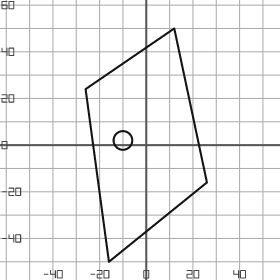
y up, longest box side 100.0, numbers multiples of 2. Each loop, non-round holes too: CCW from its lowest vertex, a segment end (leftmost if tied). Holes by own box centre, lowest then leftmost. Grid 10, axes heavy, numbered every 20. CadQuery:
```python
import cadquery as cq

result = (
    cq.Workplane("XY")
    .moveTo(-16.0, -50.0)
    .lineTo(26.0, -16.0)
    .lineTo(12.0, 50.0)
    .lineTo(-26.0, 24.0)
    .close()
    .moveTo(-10.0, 2.0)
    .circle(4.0)
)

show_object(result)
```